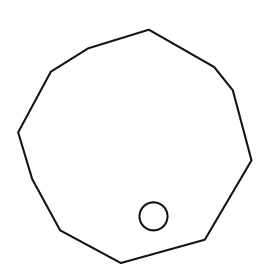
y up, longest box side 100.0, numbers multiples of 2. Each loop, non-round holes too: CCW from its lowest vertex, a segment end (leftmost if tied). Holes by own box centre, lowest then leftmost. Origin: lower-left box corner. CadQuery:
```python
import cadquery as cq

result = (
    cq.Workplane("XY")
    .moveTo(44.0, 0.0)
    .lineTo(80.0, 10.0)
    .lineTo(100.0, 44.0)
    .lineTo(92.0, 74.0)
    .lineTo(84.0, 84.0)
    .lineTo(56.0, 100.0)
    .lineTo(30.0, 92.0)
    .lineTo(14.0, 82.0)
    .lineTo(0.0, 56.0)
    .lineTo(6.0, 36.0)
    .lineTo(18.0, 14.0)
    .close()
    .moveTo(58.0, 20.0)
    .circle(6.0)
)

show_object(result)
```